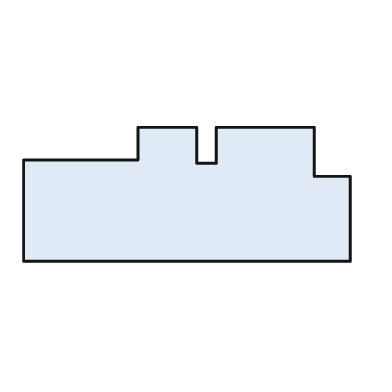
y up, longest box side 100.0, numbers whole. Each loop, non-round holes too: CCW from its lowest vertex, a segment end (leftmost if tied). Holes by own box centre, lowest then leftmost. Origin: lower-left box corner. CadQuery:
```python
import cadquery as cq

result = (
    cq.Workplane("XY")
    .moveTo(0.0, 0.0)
    .lineTo(100.0, 0.0)
    .lineTo(100.0, 26.0)
    .lineTo(89.0, 26.0)
    .lineTo(89.0, 41.0)
    .lineTo(59.0, 41.0)
    .lineTo(59.0, 30.0)
    .lineTo(53.0, 30.0)
    .lineTo(53.0, 41.0)
    .lineTo(35.0, 41.0)
    .lineTo(35.0, 31.0)
    .lineTo(0.0, 31.0)
    .close()
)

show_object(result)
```